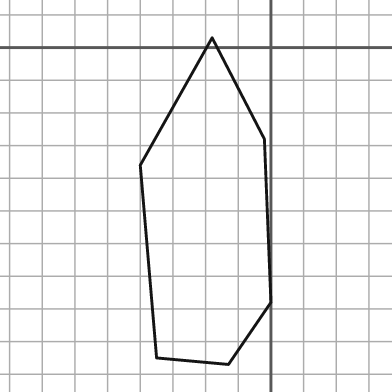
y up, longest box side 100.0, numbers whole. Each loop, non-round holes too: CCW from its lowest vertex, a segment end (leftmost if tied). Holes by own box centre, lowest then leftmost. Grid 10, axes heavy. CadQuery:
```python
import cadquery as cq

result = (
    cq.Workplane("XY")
    .moveTo(-13.0, -97.0)
    .lineTo(0.0, -78.0)
    .lineTo(-2.0, -28.0)
    .lineTo(-18.0, 3.0)
    .lineTo(-40.0, -36.0)
    .lineTo(-35.0, -95.0)
    .close()
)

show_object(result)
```